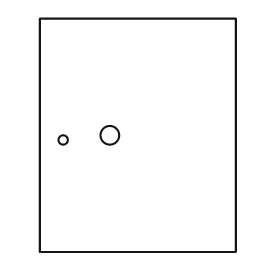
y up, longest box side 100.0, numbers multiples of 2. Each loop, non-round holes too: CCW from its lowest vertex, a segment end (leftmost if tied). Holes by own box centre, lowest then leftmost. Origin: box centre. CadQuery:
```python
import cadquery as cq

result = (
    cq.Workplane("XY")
    .moveTo(-42.0, -50.0)
    .lineTo(42.0, -50.0)
    .lineTo(42.0, 50.0)
    .lineTo(-42.0, 50.0)
    .close()
    .moveTo(-32.0, -2.0)
    .circle(2.0)
    .moveTo(-12.0, 0.0)
    .circle(4.0)
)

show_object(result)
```